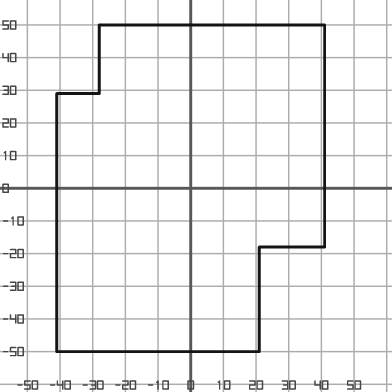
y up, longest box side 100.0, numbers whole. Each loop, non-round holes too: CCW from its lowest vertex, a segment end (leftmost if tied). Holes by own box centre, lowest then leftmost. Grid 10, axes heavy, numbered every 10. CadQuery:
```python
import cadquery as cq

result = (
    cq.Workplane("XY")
    .moveTo(-41.0, -50.0)
    .lineTo(21.0, -50.0)
    .lineTo(21.0, -18.0)
    .lineTo(41.0, -18.0)
    .lineTo(41.0, 50.0)
    .lineTo(-28.0, 50.0)
    .lineTo(-28.0, 29.0)
    .lineTo(-41.0, 29.0)
    .close()
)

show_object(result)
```